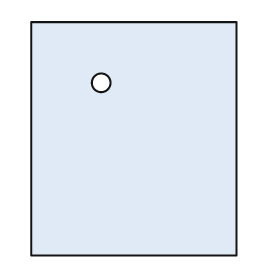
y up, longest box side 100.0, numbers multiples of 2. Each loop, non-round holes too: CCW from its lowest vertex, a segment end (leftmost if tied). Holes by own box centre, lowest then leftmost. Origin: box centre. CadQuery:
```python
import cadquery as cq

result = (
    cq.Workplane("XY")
    .moveTo(-44.0, -50.0)
    .lineTo(44.0, -50.0)
    .lineTo(44.0, 50.0)
    .lineTo(-44.0, 50.0)
    .close()
    .moveTo(-14.0, 24.0)
    .circle(4.0)
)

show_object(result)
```